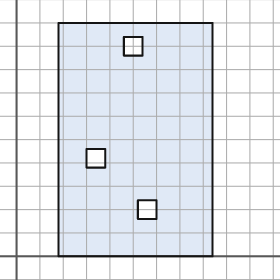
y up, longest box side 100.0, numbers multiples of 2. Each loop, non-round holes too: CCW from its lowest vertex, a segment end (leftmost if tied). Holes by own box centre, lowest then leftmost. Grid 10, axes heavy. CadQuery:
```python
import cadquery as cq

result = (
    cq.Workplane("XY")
    .moveTo(18.0, 0.0)
    .lineTo(84.0, 0.0)
    .lineTo(84.0, 100.0)
    .lineTo(18.0, 100.0)
    .close()
    .moveTo(52.0, 16.0)
    .lineTo(60.0, 16.0)
    .lineTo(60.0, 24.0)
    .lineTo(52.0, 24.0)
    .close()
    .moveTo(30.0, 38.0)
    .lineTo(38.0, 38.0)
    .lineTo(38.0, 46.0)
    .lineTo(30.0, 46.0)
    .close()
    .moveTo(46.0, 86.0)
    .lineTo(54.0, 86.0)
    .lineTo(54.0, 94.0)
    .lineTo(46.0, 94.0)
    .close()
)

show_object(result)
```